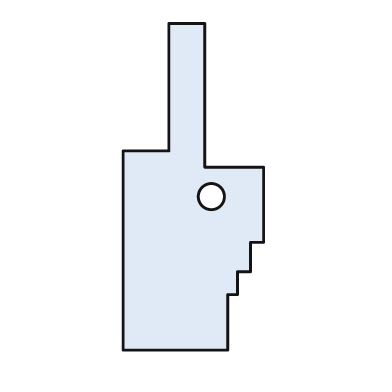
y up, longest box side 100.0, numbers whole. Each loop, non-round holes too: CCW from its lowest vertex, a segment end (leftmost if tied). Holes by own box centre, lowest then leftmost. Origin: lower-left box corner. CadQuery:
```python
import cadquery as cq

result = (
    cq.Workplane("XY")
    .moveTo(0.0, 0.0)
    .lineTo(32.0, 0.0)
    .lineTo(32.0, 17.0)
    .lineTo(35.0, 17.0)
    .lineTo(35.0, 24.0)
    .lineTo(39.0, 24.0)
    .lineTo(39.0, 33.0)
    .lineTo(43.0, 33.0)
    .lineTo(43.0, 56.0)
    .lineTo(25.0, 56.0)
    .lineTo(25.0, 100.0)
    .lineTo(14.0, 100.0)
    .lineTo(14.0, 61.0)
    .lineTo(0.0, 61.0)
    .close()
    .moveTo(27.0, 47.0)
    .circle(4.0)
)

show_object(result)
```